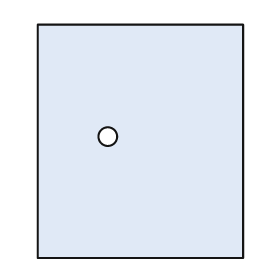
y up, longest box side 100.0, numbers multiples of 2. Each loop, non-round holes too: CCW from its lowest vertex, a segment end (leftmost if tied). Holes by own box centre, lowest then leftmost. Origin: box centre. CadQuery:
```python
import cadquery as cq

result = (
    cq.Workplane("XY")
    .moveTo(-44.0, -50.0)
    .lineTo(44.0, -50.0)
    .lineTo(44.0, 50.0)
    .lineTo(-44.0, 50.0)
    .close()
    .moveTo(-14.0, 2.0)
    .circle(4.0)
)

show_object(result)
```